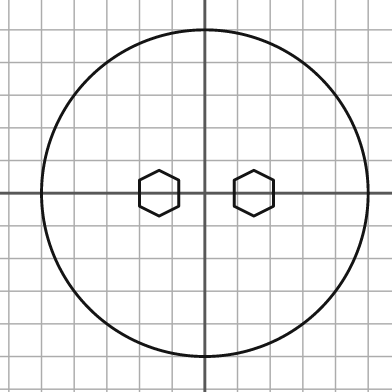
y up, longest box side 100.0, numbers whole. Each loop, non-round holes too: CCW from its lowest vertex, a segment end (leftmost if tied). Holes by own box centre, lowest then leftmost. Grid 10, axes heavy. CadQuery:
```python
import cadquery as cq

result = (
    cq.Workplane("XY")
    .moveTo(0.0, 0.0)
    .circle(50.0)
    .moveTo(-14.0, -7.0)
    .lineTo(-8.0, -4.0)
    .lineTo(-8.0, 4.0)
    .lineTo(-14.0, 7.0)
    .lineTo(-20.0, 4.0)
    .lineTo(-20.0, -4.0)
    .close()
    .moveTo(15.0, -7.0)
    .lineTo(21.0, -4.0)
    .lineTo(21.0, 4.0)
    .lineTo(15.0, 7.0)
    .lineTo(9.0, 4.0)
    .lineTo(9.0, -4.0)
    .close()
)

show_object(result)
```